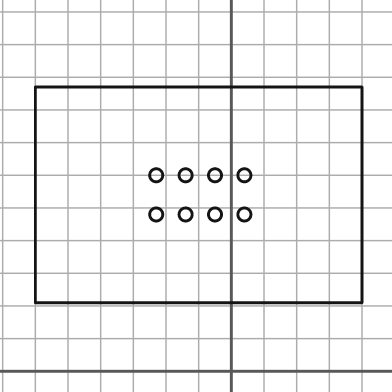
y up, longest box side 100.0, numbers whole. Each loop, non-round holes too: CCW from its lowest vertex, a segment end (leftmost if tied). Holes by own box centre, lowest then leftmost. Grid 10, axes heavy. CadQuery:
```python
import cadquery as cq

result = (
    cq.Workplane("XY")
    .moveTo(-60.0, 21.0)
    .lineTo(40.0, 21.0)
    .lineTo(40.0, 87.0)
    .lineTo(-60.0, 87.0)
    .close()
    .moveTo(-23.0, 48.0)
    .circle(2.0)
    .moveTo(-14.0, 48.0)
    .circle(2.0)
    .moveTo(-5.0, 48.0)
    .circle(2.0)
    .moveTo(4.0, 48.0)
    .circle(2.0)
    .moveTo(-23.0, 60.0)
    .circle(2.0)
    .moveTo(-14.0, 60.0)
    .circle(2.0)
    .moveTo(-5.0, 60.0)
    .circle(2.0)
    .moveTo(4.0, 60.0)
    .circle(2.0)
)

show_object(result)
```